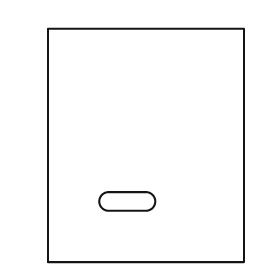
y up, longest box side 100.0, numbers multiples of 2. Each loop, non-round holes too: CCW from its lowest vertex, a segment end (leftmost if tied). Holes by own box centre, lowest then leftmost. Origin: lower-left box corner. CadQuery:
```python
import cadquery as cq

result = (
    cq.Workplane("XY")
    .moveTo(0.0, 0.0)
    .lineTo(84.0, 0.0)
    .lineTo(84.0, 100.0)
    .lineTo(0.0, 100.0)
    .close()
    .moveTo(26.0, 22.0)
    .lineTo(42.0, 22.0)
    .threePointArc((46.0, 26.0), (42.0, 30.0))
    .lineTo(26.0, 30.0)
    .threePointArc((22.0, 26.0), (26.0, 22.0))
    .close()
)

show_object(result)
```